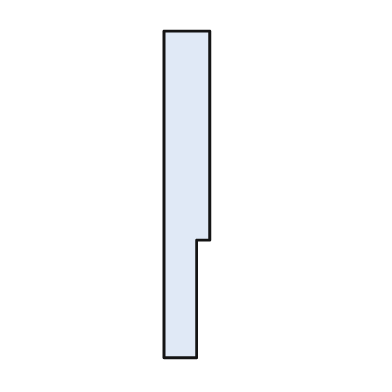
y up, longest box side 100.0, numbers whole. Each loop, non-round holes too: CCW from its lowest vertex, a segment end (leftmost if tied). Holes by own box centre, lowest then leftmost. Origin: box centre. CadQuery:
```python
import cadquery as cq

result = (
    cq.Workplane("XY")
    .moveTo(-7.0, -50.0)
    .lineTo(3.0, -50.0)
    .lineTo(3.0, -14.0)
    .lineTo(7.0, -14.0)
    .lineTo(7.0, 50.0)
    .lineTo(-7.0, 50.0)
    .close()
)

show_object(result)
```